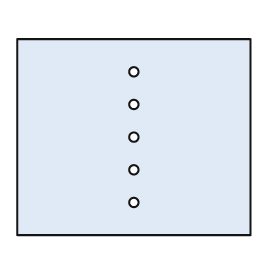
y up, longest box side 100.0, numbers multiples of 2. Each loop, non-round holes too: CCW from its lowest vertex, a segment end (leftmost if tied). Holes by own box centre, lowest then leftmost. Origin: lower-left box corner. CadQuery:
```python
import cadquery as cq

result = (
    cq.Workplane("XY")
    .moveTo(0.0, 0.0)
    .lineTo(100.0, 0.0)
    .lineTo(100.0, 84.0)
    .lineTo(0.0, 84.0)
    .close()
    .moveTo(50.0, 14.0)
    .circle(2.0)
    .moveTo(50.0, 28.0)
    .circle(2.0)
    .moveTo(50.0, 42.0)
    .circle(2.0)
    .moveTo(50.0, 56.0)
    .circle(2.0)
    .moveTo(50.0, 70.0)
    .circle(2.0)
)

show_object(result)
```